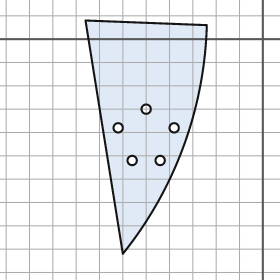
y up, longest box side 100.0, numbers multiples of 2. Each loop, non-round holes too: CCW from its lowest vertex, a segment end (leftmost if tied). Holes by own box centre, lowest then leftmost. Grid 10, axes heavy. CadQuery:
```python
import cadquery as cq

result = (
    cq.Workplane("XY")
    .moveTo(-60.0, -92.0)
    .threePointArc((-34.0, -46.0), (-24.0, 6.0))
    .lineTo(-76.0, 8.0)
    .close()
    .moveTo(-56.0, -52.0)
    .circle(2.0)
    .moveTo(-44.0, -52.0)
    .circle(2.0)
    .moveTo(-62.0, -38.0)
    .circle(2.0)
    .moveTo(-38.0, -38.0)
    .circle(2.0)
    .moveTo(-50.0, -30.0)
    .circle(2.0)
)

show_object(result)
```